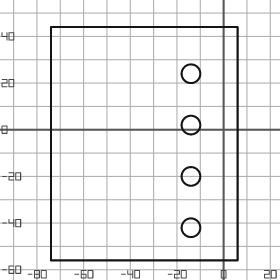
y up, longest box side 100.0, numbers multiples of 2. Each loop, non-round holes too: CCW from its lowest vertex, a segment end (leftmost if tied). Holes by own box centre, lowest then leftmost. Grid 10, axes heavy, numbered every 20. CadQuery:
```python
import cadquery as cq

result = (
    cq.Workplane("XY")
    .moveTo(-74.0, -56.0)
    .lineTo(6.0, -56.0)
    .lineTo(6.0, 44.0)
    .lineTo(-74.0, 44.0)
    .close()
    .moveTo(-14.0, -42.0)
    .circle(4.0)
    .moveTo(-14.0, -20.0)
    .circle(4.0)
    .moveTo(-14.0, 2.0)
    .circle(4.0)
    .moveTo(-14.0, 24.0)
    .circle(4.0)
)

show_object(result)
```